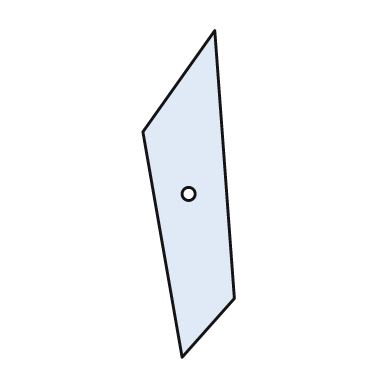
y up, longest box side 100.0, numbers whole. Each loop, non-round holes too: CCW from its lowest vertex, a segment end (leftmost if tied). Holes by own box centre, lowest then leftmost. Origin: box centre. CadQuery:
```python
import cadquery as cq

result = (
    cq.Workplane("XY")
    .moveTo(-2.0, -50.0)
    .lineTo(14.0, -32.0)
    .lineTo(8.0, 50.0)
    .lineTo(-14.0, 19.0)
    .close()
    .moveTo(0.0, 0.0)
    .circle(2.0)
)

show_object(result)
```